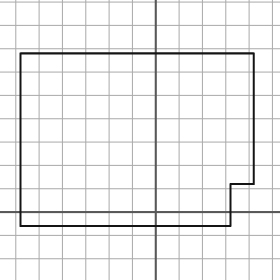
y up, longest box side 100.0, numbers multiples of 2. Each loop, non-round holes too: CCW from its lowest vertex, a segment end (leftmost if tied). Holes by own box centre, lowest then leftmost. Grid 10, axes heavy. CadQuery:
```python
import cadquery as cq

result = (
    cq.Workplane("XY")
    .moveTo(-58.0, -6.0)
    .lineTo(32.0, -6.0)
    .lineTo(32.0, 12.0)
    .lineTo(42.0, 12.0)
    .lineTo(42.0, 68.0)
    .lineTo(-58.0, 68.0)
    .close()
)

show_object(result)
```